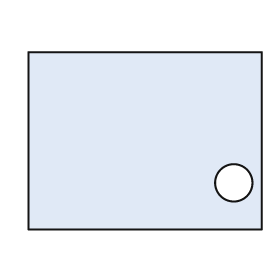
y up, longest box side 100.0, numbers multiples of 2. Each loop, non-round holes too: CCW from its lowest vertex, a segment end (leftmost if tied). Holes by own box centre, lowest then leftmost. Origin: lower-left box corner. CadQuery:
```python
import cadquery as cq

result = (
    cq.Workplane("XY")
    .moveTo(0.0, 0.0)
    .lineTo(100.0, 0.0)
    .lineTo(100.0, 76.0)
    .lineTo(0.0, 76.0)
    .close()
    .moveTo(88.0, 20.0)
    .circle(8.0)
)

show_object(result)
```